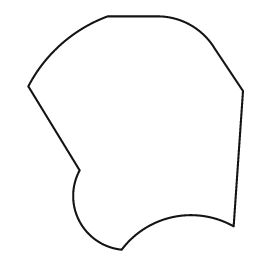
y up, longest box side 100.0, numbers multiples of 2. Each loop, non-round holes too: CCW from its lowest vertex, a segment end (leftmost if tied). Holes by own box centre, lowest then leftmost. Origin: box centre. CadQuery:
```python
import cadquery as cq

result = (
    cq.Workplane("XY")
    .moveTo(-6.0, -50.0)
    .threePointArc((16.0, -36.0), (42.0, -40.0))
    .lineTo(46.0, 18.0)
    .lineTo(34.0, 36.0)
    .threePointArc((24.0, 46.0), (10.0, 50.0))
    .lineTo(-12.0, 50.0)
    .threePointArc((-32.0, 38.0), (-46.0, 20.0))
    .lineTo(-24.0, -16.0)
    .threePointArc((-24.0, -38.0), (-6.0, -50.0))
    .close()
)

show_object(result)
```